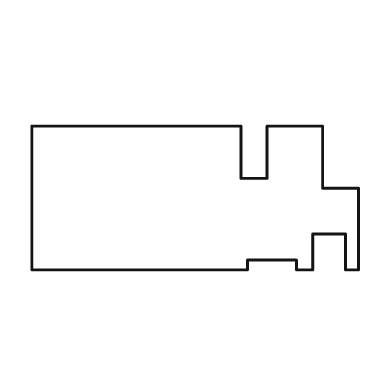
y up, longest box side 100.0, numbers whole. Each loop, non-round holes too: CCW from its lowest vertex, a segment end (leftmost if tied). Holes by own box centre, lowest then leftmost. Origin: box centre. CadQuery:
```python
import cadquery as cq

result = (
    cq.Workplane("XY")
    .moveTo(-50.0, -22.0)
    .lineTo(16.0, -22.0)
    .lineTo(16.0, -19.0)
    .lineTo(31.0, -19.0)
    .lineTo(31.0, -22.0)
    .lineTo(36.0, -22.0)
    .lineTo(36.0, -11.0)
    .lineTo(46.0, -11.0)
    .lineTo(46.0, -22.0)
    .lineTo(50.0, -22.0)
    .lineTo(50.0, 3.0)
    .lineTo(39.0, 3.0)
    .lineTo(39.0, 22.0)
    .lineTo(22.0, 22.0)
    .lineTo(22.0, 6.0)
    .lineTo(14.0, 6.0)
    .lineTo(14.0, 22.0)
    .lineTo(-50.0, 22.0)
    .close()
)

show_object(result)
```